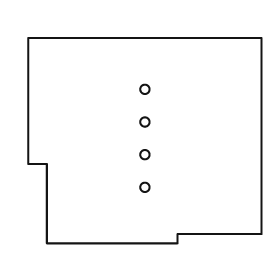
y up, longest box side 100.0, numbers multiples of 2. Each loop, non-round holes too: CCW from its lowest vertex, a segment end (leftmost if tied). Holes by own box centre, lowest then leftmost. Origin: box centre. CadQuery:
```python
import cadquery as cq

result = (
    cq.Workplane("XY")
    .moveTo(-42.0, -44.0)
    .lineTo(14.0, -44.0)
    .lineTo(14.0, -40.0)
    .lineTo(50.0, -40.0)
    .lineTo(50.0, 44.0)
    .lineTo(-50.0, 44.0)
    .lineTo(-50.0, -10.0)
    .lineTo(-42.0, -10.0)
    .close()
    .moveTo(0.0, -20.0)
    .circle(2.0)
    .moveTo(0.0, -6.0)
    .circle(2.0)
    .moveTo(0.0, 8.0)
    .circle(2.0)
    .moveTo(0.0, 22.0)
    .circle(2.0)
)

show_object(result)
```